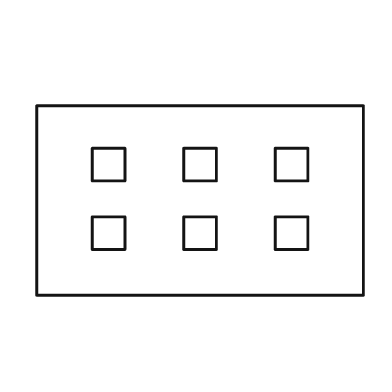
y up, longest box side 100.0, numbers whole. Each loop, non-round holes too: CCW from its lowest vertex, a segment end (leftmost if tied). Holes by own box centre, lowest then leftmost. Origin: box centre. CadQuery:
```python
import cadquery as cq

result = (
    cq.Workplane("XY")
    .moveTo(-50.0, -29.0)
    .lineTo(50.0, -29.0)
    .lineTo(50.0, 29.0)
    .lineTo(-50.0, 29.0)
    .close()
    .moveTo(-33.0, -15.0)
    .lineTo(-23.0, -15.0)
    .lineTo(-23.0, -5.0)
    .lineTo(-33.0, -5.0)
    .close()
    .moveTo(-5.0, -15.0)
    .lineTo(5.0, -15.0)
    .lineTo(5.0, -5.0)
    .lineTo(-5.0, -5.0)
    .close()
    .moveTo(23.0, -15.0)
    .lineTo(33.0, -15.0)
    .lineTo(33.0, -5.0)
    .lineTo(23.0, -5.0)
    .close()
    .moveTo(-33.0, 6.0)
    .lineTo(-23.0, 6.0)
    .lineTo(-23.0, 16.0)
    .lineTo(-33.0, 16.0)
    .close()
    .moveTo(-5.0, 6.0)
    .lineTo(5.0, 6.0)
    .lineTo(5.0, 16.0)
    .lineTo(-5.0, 16.0)
    .close()
    .moveTo(23.0, 6.0)
    .lineTo(33.0, 6.0)
    .lineTo(33.0, 16.0)
    .lineTo(23.0, 16.0)
    .close()
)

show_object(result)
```